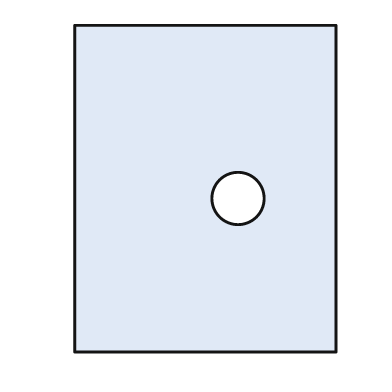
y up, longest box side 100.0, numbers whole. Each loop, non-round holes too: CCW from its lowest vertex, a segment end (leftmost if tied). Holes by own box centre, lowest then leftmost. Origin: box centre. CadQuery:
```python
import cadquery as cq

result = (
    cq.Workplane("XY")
    .moveTo(-40.0, -50.0)
    .lineTo(40.0, -50.0)
    .lineTo(40.0, 50.0)
    .lineTo(-40.0, 50.0)
    .close()
    .moveTo(10.0, -3.0)
    .circle(8.0)
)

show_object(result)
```